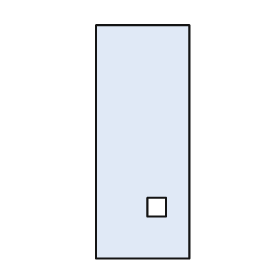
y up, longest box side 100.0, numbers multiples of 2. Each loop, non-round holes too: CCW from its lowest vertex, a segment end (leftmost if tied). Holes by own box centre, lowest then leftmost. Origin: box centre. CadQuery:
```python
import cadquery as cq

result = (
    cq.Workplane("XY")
    .moveTo(-20.0, -50.0)
    .lineTo(20.0, -50.0)
    .lineTo(20.0, 50.0)
    .lineTo(-20.0, 50.0)
    .close()
    .moveTo(2.0, -32.0)
    .lineTo(10.0, -32.0)
    .lineTo(10.0, -24.0)
    .lineTo(2.0, -24.0)
    .close()
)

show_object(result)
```